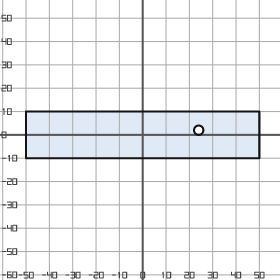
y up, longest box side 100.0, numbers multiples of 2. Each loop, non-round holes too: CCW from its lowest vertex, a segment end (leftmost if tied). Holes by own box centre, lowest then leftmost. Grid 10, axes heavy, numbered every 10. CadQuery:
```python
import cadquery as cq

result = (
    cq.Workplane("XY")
    .moveTo(-50.0, -10.0)
    .lineTo(50.0, -10.0)
    .lineTo(50.0, 10.0)
    .lineTo(-50.0, 10.0)
    .close()
    .moveTo(24.0, 2.0)
    .circle(2.0)
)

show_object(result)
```